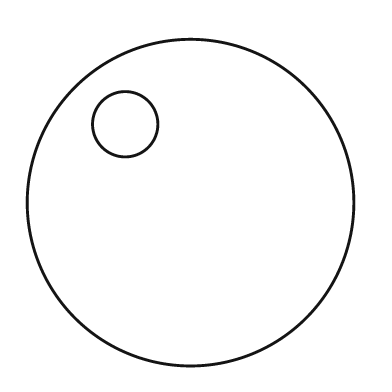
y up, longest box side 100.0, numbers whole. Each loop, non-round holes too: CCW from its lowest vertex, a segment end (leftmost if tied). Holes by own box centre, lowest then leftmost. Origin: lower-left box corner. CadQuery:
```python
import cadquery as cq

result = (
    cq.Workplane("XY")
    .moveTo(50.0, 50.0)
    .circle(50.0)
    .moveTo(30.0, 74.0)
    .circle(10.0)
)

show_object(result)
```